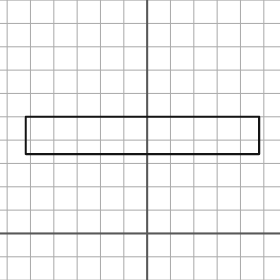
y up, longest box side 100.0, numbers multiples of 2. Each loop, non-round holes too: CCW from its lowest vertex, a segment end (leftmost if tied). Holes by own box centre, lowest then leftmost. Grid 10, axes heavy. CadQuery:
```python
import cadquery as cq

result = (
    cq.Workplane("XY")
    .moveTo(-52.0, 34.0)
    .lineTo(48.0, 34.0)
    .lineTo(48.0, 50.0)
    .lineTo(-52.0, 50.0)
    .close()
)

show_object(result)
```